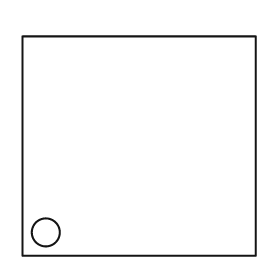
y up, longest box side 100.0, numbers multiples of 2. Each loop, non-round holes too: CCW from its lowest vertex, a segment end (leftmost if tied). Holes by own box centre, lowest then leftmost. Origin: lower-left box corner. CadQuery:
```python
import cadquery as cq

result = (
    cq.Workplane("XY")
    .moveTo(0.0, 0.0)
    .lineTo(100.0, 0.0)
    .lineTo(100.0, 94.0)
    .lineTo(0.0, 94.0)
    .close()
    .moveTo(10.0, 10.0)
    .circle(6.0)
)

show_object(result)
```